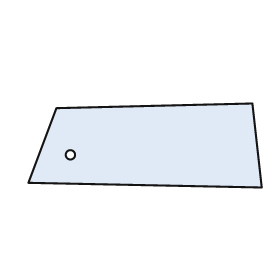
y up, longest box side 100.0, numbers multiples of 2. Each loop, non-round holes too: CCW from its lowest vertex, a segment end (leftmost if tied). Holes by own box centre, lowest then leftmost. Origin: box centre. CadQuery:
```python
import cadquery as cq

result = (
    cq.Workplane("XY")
    .moveTo(50.0, -18.0)
    .lineTo(46.0, 18.0)
    .lineTo(-38.0, 16.0)
    .lineTo(-50.0, -16.0)
    .close()
    .moveTo(-32.0, -4.0)
    .circle(2.0)
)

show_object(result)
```